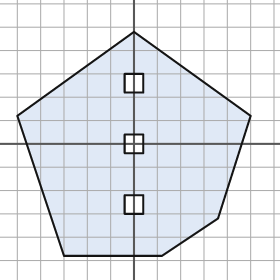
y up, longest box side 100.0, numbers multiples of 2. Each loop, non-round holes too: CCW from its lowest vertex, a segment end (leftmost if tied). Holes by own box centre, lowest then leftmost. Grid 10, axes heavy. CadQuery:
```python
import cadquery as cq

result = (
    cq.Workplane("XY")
    .moveTo(-30.0, -48.0)
    .lineTo(12.0, -48.0)
    .lineTo(36.0, -32.0)
    .lineTo(50.0, 12.0)
    .lineTo(0.0, 48.0)
    .lineTo(-50.0, 12.0)
    .close()
    .moveTo(-4.0, -30.0)
    .lineTo(4.0, -30.0)
    .lineTo(4.0, -22.0)
    .lineTo(-4.0, -22.0)
    .close()
    .moveTo(-4.0, -4.0)
    .lineTo(4.0, -4.0)
    .lineTo(4.0, 4.0)
    .lineTo(-4.0, 4.0)
    .close()
    .moveTo(-4.0, 22.0)
    .lineTo(4.0, 22.0)
    .lineTo(4.0, 30.0)
    .lineTo(-4.0, 30.0)
    .close()
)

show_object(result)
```